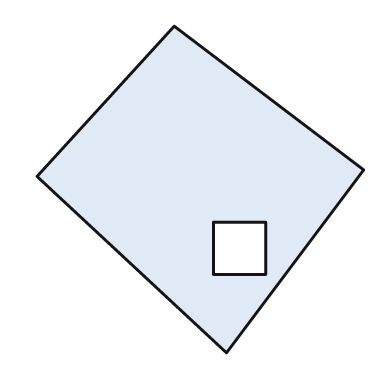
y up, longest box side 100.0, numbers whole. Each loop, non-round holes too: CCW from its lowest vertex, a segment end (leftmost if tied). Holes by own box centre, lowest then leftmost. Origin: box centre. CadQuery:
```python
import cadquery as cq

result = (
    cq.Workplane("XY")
    .moveTo(8.0, -50.0)
    .lineTo(50.0, 6.0)
    .lineTo(-8.0, 50.0)
    .lineTo(-50.0, 4.0)
    .close()
    .moveTo(4.0, -26.0)
    .lineTo(20.0, -26.0)
    .lineTo(20.0, -10.0)
    .lineTo(4.0, -10.0)
    .close()
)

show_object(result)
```